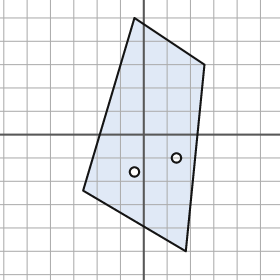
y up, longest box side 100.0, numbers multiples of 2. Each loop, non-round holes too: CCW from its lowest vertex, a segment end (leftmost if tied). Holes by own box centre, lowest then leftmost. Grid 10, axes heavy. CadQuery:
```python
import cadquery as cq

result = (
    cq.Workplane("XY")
    .moveTo(18.0, -50.0)
    .lineTo(26.0, 30.0)
    .lineTo(-4.0, 50.0)
    .lineTo(-26.0, -24.0)
    .close()
    .moveTo(-4.0, -16.0)
    .circle(2.0)
    .moveTo(14.0, -10.0)
    .circle(2.0)
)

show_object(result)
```